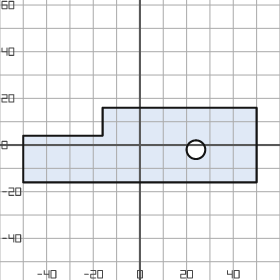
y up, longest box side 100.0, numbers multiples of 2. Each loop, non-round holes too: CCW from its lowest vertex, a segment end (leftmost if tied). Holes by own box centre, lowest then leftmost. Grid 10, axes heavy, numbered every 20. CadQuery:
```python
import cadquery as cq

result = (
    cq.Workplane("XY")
    .moveTo(-50.0, -16.0)
    .lineTo(50.0, -16.0)
    .lineTo(50.0, 16.0)
    .lineTo(-16.0, 16.0)
    .lineTo(-16.0, 4.0)
    .lineTo(-50.0, 4.0)
    .close()
    .moveTo(24.0, -2.0)
    .circle(4.0)
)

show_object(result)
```